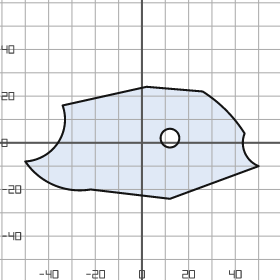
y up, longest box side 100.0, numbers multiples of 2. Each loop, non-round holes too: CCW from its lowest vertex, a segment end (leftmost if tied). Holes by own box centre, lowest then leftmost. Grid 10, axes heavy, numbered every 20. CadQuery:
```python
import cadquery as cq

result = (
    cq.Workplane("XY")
    .moveTo(12.0, -24.0)
    .lineTo(50.0, -10.0)
    .threePointArc((44.0, -4.0), (44.0, 4.0))
    .threePointArc((36.0, 14.0), (26.0, 22.0))
    .lineTo(2.0, 24.0)
    .lineTo(-34.0, 16.0)
    .threePointArc((-36.0, 0.0), (-50.0, -8.0))
    .threePointArc((-38.0, -18.0), (-22.0, -20.0))
    .close()
    .moveTo(12.0, 2.0)
    .circle(4.0)
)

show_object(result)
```